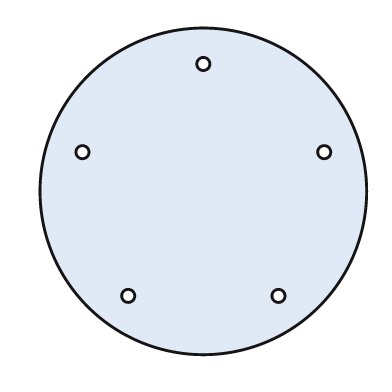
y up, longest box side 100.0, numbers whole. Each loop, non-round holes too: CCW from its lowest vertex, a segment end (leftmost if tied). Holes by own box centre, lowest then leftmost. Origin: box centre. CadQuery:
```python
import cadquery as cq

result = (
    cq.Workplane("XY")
    .moveTo(0.0, 0.0)
    .circle(50.0)
    .moveTo(-23.0, -32.0)
    .circle(2.0)
    .moveTo(23.0, -32.0)
    .circle(2.0)
    .moveTo(-37.0, 12.0)
    .circle(2.0)
    .moveTo(37.0, 12.0)
    .circle(2.0)
    .moveTo(0.0, 39.0)
    .circle(2.0)
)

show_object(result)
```